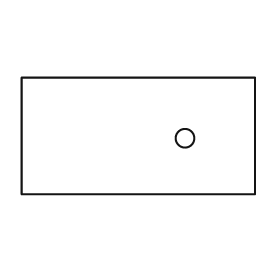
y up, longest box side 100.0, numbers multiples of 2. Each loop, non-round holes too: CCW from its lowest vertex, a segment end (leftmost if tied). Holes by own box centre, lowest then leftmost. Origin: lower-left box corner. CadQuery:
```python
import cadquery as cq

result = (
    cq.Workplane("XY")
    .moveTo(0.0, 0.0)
    .lineTo(100.0, 0.0)
    .lineTo(100.0, 50.0)
    .lineTo(0.0, 50.0)
    .close()
    .moveTo(70.0, 24.0)
    .circle(4.0)
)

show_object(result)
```